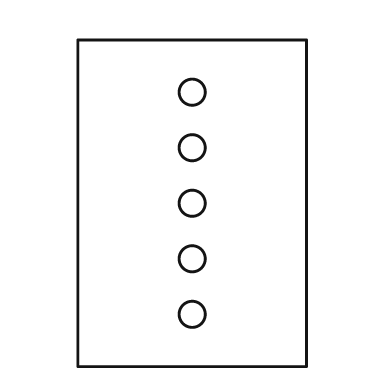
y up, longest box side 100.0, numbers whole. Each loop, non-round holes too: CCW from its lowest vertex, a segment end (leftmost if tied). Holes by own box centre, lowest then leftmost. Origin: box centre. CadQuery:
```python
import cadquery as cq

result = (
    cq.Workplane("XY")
    .moveTo(-35.0, -50.0)
    .lineTo(35.0, -50.0)
    .lineTo(35.0, 50.0)
    .lineTo(-35.0, 50.0)
    .close()
    .moveTo(0.0, -34.0)
    .circle(4.0)
    .moveTo(0.0, -17.0)
    .circle(4.0)
    .moveTo(0.0, 0.0)
    .circle(4.0)
    .moveTo(0.0, 17.0)
    .circle(4.0)
    .moveTo(0.0, 34.0)
    .circle(4.0)
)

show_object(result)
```